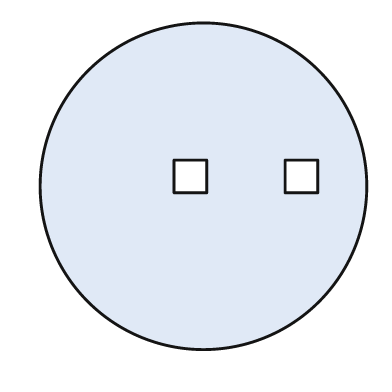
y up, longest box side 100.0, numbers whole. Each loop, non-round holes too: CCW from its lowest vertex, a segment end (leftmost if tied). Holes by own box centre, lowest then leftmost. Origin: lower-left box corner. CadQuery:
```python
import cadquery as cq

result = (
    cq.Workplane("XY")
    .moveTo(50.0, 50.0)
    .circle(50.0)
    .moveTo(41.0, 48.0)
    .lineTo(51.0, 48.0)
    .lineTo(51.0, 58.0)
    .lineTo(41.0, 58.0)
    .close()
    .moveTo(75.0, 48.0)
    .lineTo(85.0, 48.0)
    .lineTo(85.0, 58.0)
    .lineTo(75.0, 58.0)
    .close()
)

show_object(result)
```